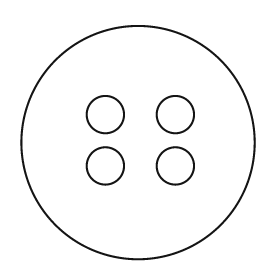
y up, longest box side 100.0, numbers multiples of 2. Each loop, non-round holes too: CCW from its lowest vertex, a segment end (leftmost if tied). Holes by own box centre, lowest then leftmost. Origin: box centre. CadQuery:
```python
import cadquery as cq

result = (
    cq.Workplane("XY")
    .moveTo(0.0, 0.0)
    .circle(50.0)
    .moveTo(-14.0, -10.0)
    .circle(8.0)
    .moveTo(16.0, -10.0)
    .circle(8.0)
    .moveTo(-14.0, 12.0)
    .circle(8.0)
    .moveTo(16.0, 12.0)
    .circle(8.0)
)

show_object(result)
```